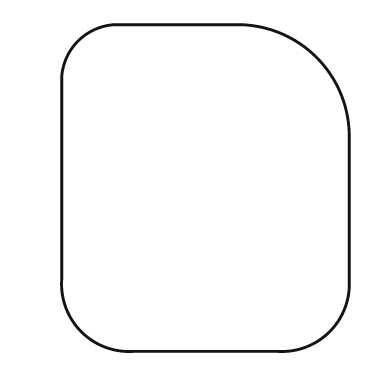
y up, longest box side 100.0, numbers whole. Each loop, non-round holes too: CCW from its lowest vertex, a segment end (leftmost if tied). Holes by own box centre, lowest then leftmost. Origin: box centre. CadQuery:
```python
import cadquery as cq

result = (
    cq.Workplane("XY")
    .moveTo(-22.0, -50.0)
    .lineTo(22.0, -50.0)
    .threePointArc((38.0, -44.0), (44.0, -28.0))
    .lineTo(44.0, 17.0)
    .threePointArc((34.0, 40.0), (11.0, 50.0))
    .lineTo(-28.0, 50.0)
    .threePointArc((-39.0, 45.0), (-44.0, 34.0))
    .lineTo(-44.0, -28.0)
    .threePointArc((-38.0, -44.0), (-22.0, -50.0))
    .close()
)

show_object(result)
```